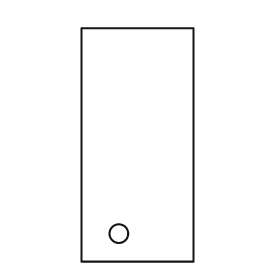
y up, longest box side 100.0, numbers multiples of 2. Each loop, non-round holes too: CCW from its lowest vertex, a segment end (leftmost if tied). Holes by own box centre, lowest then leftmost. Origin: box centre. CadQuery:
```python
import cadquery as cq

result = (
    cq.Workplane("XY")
    .moveTo(-24.0, -50.0)
    .lineTo(24.0, -50.0)
    .lineTo(24.0, 50.0)
    .lineTo(-24.0, 50.0)
    .close()
    .moveTo(-8.0, -38.0)
    .circle(4.0)
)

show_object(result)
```